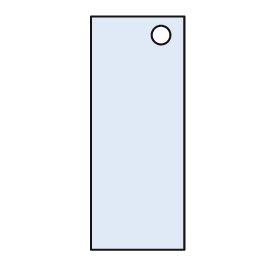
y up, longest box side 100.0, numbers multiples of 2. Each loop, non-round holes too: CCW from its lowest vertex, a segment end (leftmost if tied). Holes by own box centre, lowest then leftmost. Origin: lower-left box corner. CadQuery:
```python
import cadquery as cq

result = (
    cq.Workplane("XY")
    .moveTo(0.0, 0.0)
    .lineTo(40.0, 0.0)
    .lineTo(40.0, 100.0)
    .lineTo(0.0, 100.0)
    .close()
    .moveTo(30.0, 92.0)
    .circle(4.0)
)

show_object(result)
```